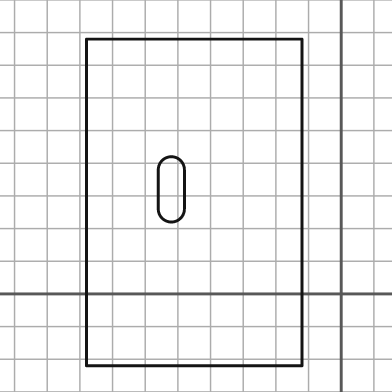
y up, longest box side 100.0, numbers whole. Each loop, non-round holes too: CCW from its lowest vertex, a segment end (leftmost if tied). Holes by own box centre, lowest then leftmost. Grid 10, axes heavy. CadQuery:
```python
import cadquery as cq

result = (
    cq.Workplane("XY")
    .moveTo(-78.0, -22.0)
    .lineTo(-12.0, -22.0)
    .lineTo(-12.0, 78.0)
    .lineTo(-78.0, 78.0)
    .close()
    .moveTo(-56.0, 26.0)
    .threePointArc((-52.0, 22.0), (-48.0, 26.0))
    .lineTo(-48.0, 38.0)
    .threePointArc((-52.0, 42.0), (-56.0, 38.0))
    .close()
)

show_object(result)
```